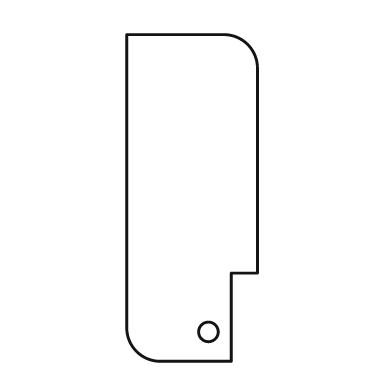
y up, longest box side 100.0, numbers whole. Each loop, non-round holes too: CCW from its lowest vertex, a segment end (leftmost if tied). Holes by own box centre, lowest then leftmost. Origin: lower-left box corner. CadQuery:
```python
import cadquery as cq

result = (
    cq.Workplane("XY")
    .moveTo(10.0, 0.0)
    .lineTo(32.0, 0.0)
    .lineTo(32.0, 27.0)
    .lineTo(40.0, 27.0)
    .lineTo(40.0, 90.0)
    .threePointArc((37.0, 97.0), (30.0, 100.0))
    .lineTo(0.0, 100.0)
    .lineTo(0.0, 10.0)
    .threePointArc((3.0, 3.0), (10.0, 0.0))
    .close()
    .moveTo(25.0, 9.0)
    .circle(3.0)
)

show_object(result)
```